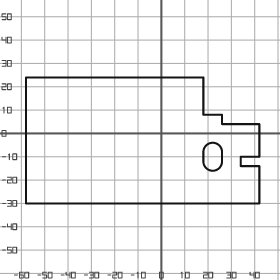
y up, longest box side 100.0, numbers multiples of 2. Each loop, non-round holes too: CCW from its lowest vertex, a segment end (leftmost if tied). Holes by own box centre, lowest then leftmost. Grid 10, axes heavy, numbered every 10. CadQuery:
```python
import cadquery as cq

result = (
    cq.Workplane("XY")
    .moveTo(-58.0, -30.0)
    .lineTo(42.0, -30.0)
    .lineTo(42.0, -14.0)
    .lineTo(34.0, -14.0)
    .lineTo(34.0, -10.0)
    .lineTo(42.0, -10.0)
    .lineTo(42.0, 4.0)
    .lineTo(26.0, 4.0)
    .lineTo(26.0, 8.0)
    .lineTo(18.0, 8.0)
    .lineTo(18.0, 24.0)
    .lineTo(-58.0, 24.0)
    .close()
    .moveTo(18.0, -12.0)
    .threePointArc((22.0, -16.0), (26.0, -12.0))
    .lineTo(26.0, -8.0)
    .threePointArc((22.0, -4.0), (18.0, -8.0))
    .close()
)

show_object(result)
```